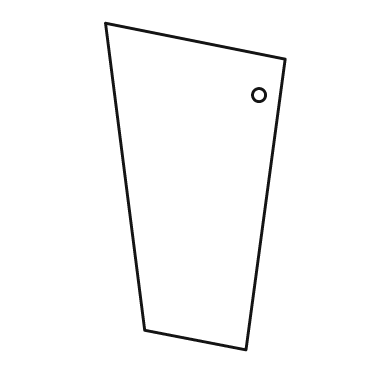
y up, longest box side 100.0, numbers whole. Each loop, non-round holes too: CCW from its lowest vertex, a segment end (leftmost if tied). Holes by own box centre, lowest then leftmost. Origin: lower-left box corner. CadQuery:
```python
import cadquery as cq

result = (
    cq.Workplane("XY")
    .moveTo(43.0, 0.0)
    .lineTo(55.0, 89.0)
    .lineTo(0.0, 100.0)
    .lineTo(12.0, 6.0)
    .close()
    .moveTo(47.0, 78.0)
    .circle(2.0)
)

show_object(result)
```